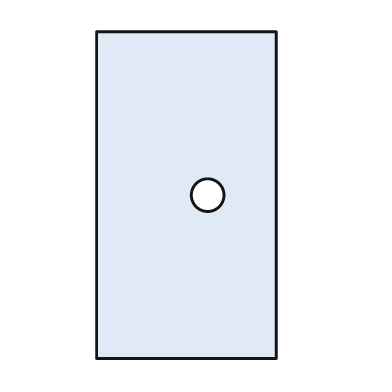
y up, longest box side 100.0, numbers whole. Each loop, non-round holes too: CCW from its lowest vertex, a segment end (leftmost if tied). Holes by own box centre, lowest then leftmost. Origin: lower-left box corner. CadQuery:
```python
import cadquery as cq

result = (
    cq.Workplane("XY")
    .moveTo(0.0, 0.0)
    .lineTo(55.0, 0.0)
    .lineTo(55.0, 100.0)
    .lineTo(0.0, 100.0)
    .close()
    .moveTo(34.0, 50.0)
    .circle(5.0)
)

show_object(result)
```